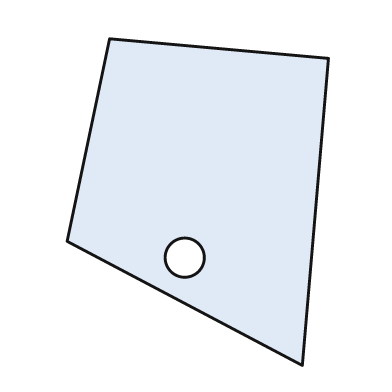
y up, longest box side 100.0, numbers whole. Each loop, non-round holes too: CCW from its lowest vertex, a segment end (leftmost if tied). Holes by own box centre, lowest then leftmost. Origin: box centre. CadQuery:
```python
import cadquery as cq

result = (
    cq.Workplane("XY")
    .moveTo(32.0, -50.0)
    .lineTo(40.0, 44.0)
    .lineTo(-27.0, 50.0)
    .lineTo(-40.0, -12.0)
    .close()
    .moveTo(-4.0, -17.0)
    .circle(6.0)
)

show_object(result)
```